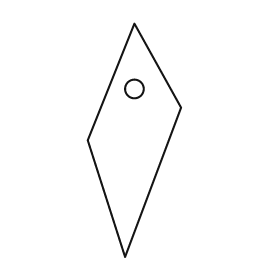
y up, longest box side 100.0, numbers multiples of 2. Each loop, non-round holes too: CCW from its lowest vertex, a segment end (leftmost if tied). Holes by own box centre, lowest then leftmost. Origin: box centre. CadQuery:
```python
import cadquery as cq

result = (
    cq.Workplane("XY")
    .moveTo(-4.0, -50.0)
    .lineTo(20.0, 14.0)
    .lineTo(0.0, 50.0)
    .lineTo(-20.0, 0.0)
    .close()
    .moveTo(0.0, 22.0)
    .circle(4.0)
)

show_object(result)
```